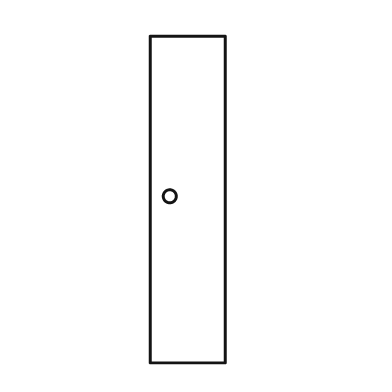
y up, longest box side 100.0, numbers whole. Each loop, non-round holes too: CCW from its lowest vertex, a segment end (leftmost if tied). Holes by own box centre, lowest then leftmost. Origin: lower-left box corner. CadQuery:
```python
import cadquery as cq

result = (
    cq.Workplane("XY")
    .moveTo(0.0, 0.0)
    .lineTo(23.0, 0.0)
    .lineTo(23.0, 100.0)
    .lineTo(0.0, 100.0)
    .close()
    .moveTo(6.0, 51.0)
    .circle(2.0)
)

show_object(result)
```